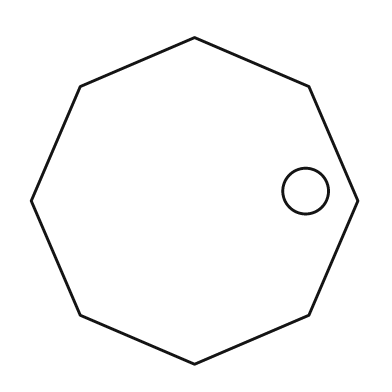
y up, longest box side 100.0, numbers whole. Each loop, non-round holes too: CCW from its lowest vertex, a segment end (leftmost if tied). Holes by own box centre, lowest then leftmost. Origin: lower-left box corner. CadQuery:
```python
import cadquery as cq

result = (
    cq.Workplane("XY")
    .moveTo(50.0, 0.0)
    .lineTo(85.0, 15.0)
    .lineTo(100.0, 50.0)
    .lineTo(85.0, 85.0)
    .lineTo(50.0, 100.0)
    .lineTo(15.0, 85.0)
    .lineTo(0.0, 50.0)
    .lineTo(15.0, 15.0)
    .close()
    .moveTo(84.0, 53.0)
    .circle(7.0)
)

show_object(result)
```